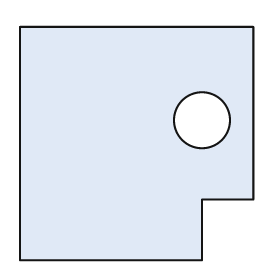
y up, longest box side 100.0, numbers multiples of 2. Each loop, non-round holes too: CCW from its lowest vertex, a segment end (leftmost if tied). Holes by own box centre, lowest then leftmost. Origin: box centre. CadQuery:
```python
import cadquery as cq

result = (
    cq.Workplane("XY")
    .moveTo(-50.0, -50.0)
    .lineTo(28.0, -50.0)
    .lineTo(28.0, -24.0)
    .lineTo(50.0, -24.0)
    .lineTo(50.0, 50.0)
    .lineTo(-50.0, 50.0)
    .close()
    .moveTo(28.0, 10.0)
    .circle(12.0)
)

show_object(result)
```